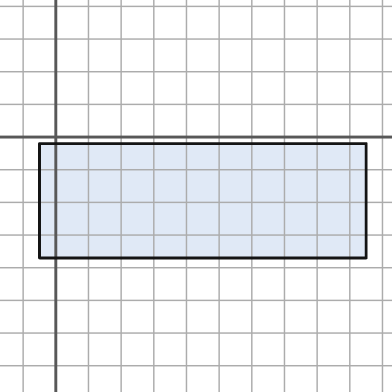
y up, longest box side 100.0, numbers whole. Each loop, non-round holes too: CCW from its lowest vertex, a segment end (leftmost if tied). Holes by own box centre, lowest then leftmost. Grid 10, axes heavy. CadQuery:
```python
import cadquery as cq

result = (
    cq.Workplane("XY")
    .moveTo(-5.0, -37.0)
    .lineTo(95.0, -37.0)
    .lineTo(95.0, -2.0)
    .lineTo(-5.0, -2.0)
    .close()
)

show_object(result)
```